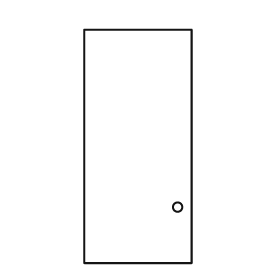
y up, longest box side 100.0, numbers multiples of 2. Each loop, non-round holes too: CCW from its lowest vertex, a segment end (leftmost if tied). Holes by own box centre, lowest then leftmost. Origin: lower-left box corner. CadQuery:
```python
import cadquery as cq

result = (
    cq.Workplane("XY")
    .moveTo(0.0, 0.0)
    .lineTo(46.0, 0.0)
    .lineTo(46.0, 100.0)
    .lineTo(0.0, 100.0)
    .close()
    .moveTo(40.0, 24.0)
    .circle(2.0)
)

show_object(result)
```